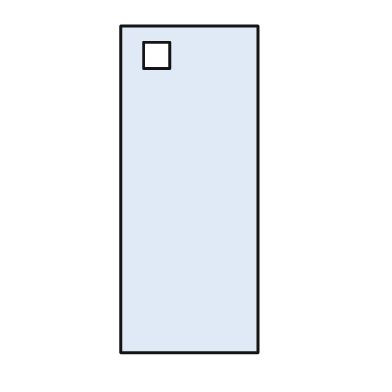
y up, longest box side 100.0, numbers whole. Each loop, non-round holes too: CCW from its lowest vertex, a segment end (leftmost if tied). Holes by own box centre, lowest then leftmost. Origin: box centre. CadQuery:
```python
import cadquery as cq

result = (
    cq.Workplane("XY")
    .moveTo(-21.0, -50.0)
    .lineTo(21.0, -50.0)
    .lineTo(21.0, 50.0)
    .lineTo(-21.0, 50.0)
    .close()
    .moveTo(-14.0, 37.0)
    .lineTo(-6.0, 37.0)
    .lineTo(-6.0, 45.0)
    .lineTo(-14.0, 45.0)
    .close()
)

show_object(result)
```